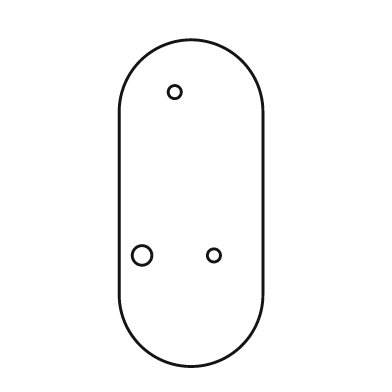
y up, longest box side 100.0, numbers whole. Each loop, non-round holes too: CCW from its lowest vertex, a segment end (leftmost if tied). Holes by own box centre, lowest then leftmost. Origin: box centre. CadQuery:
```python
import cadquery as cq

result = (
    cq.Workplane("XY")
    .moveTo(-22.0, -28.0)
    .threePointArc((0.0, -50.0), (22.0, -28.0))
    .lineTo(22.0, 28.0)
    .threePointArc((0.0, 50.0), (-22.0, 28.0))
    .close()
    .moveTo(-15.0, -16.0)
    .circle(3.0)
    .moveTo(7.0, -16.0)
    .circle(2.0)
    .moveTo(-5.0, 34.0)
    .circle(2.0)
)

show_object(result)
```